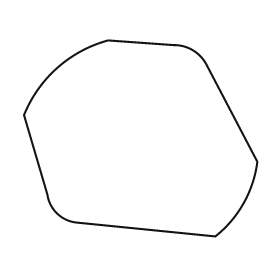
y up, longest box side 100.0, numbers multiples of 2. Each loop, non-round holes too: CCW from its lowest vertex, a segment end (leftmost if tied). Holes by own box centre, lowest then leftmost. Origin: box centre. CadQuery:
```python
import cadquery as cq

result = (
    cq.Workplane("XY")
    .moveTo(32.0, -42.0)
    .threePointArc((44.0, -28.0), (50.0, -10.0))
    .lineTo(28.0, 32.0)
    .threePointArc((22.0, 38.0), (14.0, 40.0))
    .lineTo(-14.0, 42.0)
    .threePointArc((-36.0, 30.0), (-50.0, 10.0))
    .lineTo(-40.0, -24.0)
    .threePointArc((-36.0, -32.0), (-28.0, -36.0))
    .close()
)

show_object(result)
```